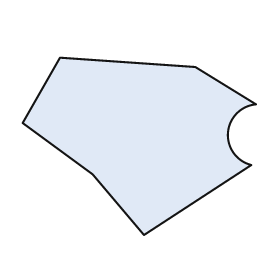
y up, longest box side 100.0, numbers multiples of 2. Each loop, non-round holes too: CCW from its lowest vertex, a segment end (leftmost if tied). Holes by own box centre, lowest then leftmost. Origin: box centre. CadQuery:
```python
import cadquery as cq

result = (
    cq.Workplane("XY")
    .moveTo(2.0, -38.0)
    .lineTo(48.0, -8.0)
    .threePointArc((38.0, 6.0), (50.0, 18.0))
    .lineTo(24.0, 34.0)
    .lineTo(-34.0, 38.0)
    .lineTo(-50.0, 10.0)
    .lineTo(-20.0, -12.0)
    .close()
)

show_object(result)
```